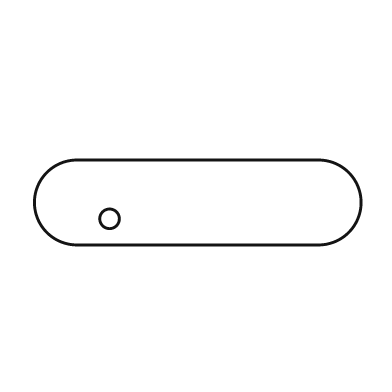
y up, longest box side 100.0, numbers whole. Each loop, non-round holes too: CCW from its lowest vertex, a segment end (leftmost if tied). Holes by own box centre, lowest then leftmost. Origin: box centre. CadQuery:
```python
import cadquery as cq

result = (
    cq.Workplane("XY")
    .moveTo(-37.0, -13.0)
    .lineTo(37.0, -13.0)
    .threePointArc((50.0, 0.0), (37.0, 13.0))
    .lineTo(-37.0, 13.0)
    .threePointArc((-50.0, 0.0), (-37.0, -13.0))
    .close()
    .moveTo(-27.0, -5.0)
    .circle(3.0)
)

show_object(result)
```